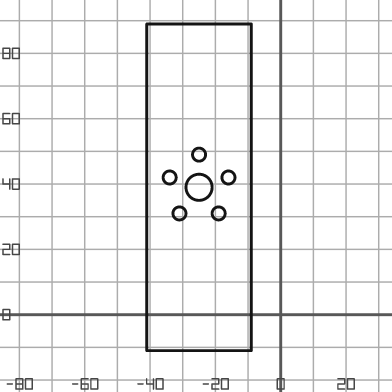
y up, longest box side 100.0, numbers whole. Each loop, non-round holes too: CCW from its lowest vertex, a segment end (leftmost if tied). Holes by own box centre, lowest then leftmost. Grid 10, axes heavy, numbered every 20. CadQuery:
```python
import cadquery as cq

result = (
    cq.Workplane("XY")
    .moveTo(-41.0, -11.0)
    .lineTo(-9.0, -11.0)
    .lineTo(-9.0, 89.0)
    .lineTo(-41.0, 89.0)
    .close()
    .moveTo(-31.0, 31.0)
    .circle(2.0)
    .moveTo(-19.0, 31.0)
    .circle(2.0)
    .moveTo(-25.0, 39.0)
    .circle(4.0)
    .moveTo(-34.0, 42.0)
    .circle(2.0)
    .moveTo(-16.0, 42.0)
    .circle(2.0)
    .moveTo(-25.0, 49.0)
    .circle(2.0)
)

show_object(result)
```